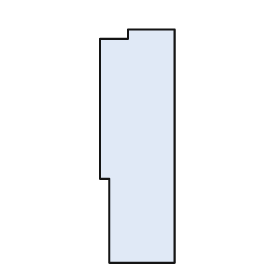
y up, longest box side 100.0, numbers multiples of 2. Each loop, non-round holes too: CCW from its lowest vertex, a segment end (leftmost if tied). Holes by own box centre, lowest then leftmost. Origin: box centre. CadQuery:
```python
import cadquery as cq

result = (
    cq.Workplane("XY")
    .moveTo(-12.0, -50.0)
    .lineTo(16.0, -50.0)
    .lineTo(16.0, 50.0)
    .lineTo(-4.0, 50.0)
    .lineTo(-4.0, 46.0)
    .lineTo(-16.0, 46.0)
    .lineTo(-16.0, -14.0)
    .lineTo(-12.0, -14.0)
    .close()
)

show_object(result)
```